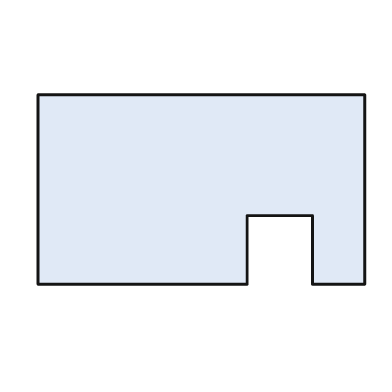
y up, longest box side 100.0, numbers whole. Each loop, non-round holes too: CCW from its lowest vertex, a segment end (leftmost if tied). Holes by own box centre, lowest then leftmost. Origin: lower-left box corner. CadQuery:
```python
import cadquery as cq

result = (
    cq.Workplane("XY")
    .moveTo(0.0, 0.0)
    .lineTo(64.0, 0.0)
    .lineTo(64.0, 21.0)
    .lineTo(84.0, 21.0)
    .lineTo(84.0, 0.0)
    .lineTo(100.0, 0.0)
    .lineTo(100.0, 58.0)
    .lineTo(0.0, 58.0)
    .close()
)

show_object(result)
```